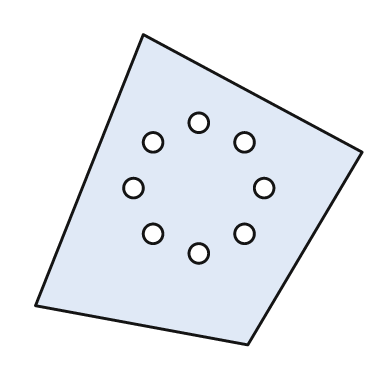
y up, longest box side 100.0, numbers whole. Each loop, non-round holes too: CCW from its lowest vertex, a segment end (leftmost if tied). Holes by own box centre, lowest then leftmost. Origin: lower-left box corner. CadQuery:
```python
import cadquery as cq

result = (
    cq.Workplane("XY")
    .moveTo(65.0, 0.0)
    .lineTo(100.0, 59.0)
    .lineTo(33.0, 95.0)
    .lineTo(0.0, 12.0)
    .close()
    .moveTo(50.0, 28.0)
    .circle(3.0)
    .moveTo(36.0, 34.0)
    .circle(3.0)
    .moveTo(64.0, 34.0)
    .circle(3.0)
    .moveTo(30.0, 48.0)
    .circle(3.0)
    .moveTo(70.0, 48.0)
    .circle(3.0)
    .moveTo(36.0, 62.0)
    .circle(3.0)
    .moveTo(64.0, 62.0)
    .circle(3.0)
    .moveTo(50.0, 68.0)
    .circle(3.0)
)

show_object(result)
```